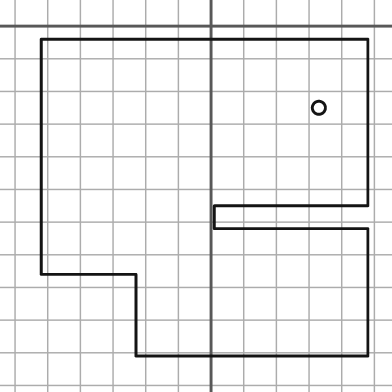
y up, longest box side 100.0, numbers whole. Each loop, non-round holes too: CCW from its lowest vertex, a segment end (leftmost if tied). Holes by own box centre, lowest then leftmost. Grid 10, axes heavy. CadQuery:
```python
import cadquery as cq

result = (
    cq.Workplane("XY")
    .moveTo(-23.0, -101.0)
    .lineTo(48.0, -101.0)
    .lineTo(48.0, -62.0)
    .lineTo(1.0, -62.0)
    .lineTo(1.0, -55.0)
    .lineTo(48.0, -55.0)
    .lineTo(48.0, -4.0)
    .lineTo(-52.0, -4.0)
    .lineTo(-52.0, -76.0)
    .lineTo(-23.0, -76.0)
    .close()
    .moveTo(33.0, -25.0)
    .circle(2.0)
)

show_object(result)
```